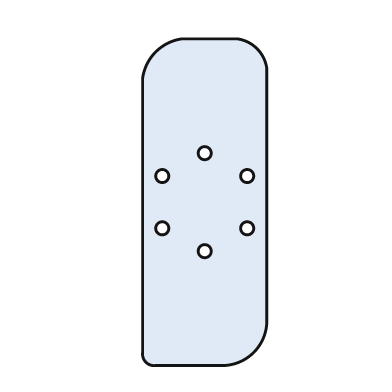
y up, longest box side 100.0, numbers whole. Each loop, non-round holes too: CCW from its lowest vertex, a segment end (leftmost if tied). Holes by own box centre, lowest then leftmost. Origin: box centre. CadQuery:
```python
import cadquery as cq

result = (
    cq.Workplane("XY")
    .moveTo(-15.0, -50.0)
    .lineTo(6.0, -50.0)
    .threePointArc((15.0, -46.0), (19.0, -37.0))
    .lineTo(19.0, 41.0)
    .threePointArc((16.0, 47.0), (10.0, 50.0))
    .lineTo(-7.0, 50.0)
    .threePointArc((-15.0, 46.0), (-19.0, 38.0))
    .lineTo(-19.0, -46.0)
    .threePointArc((-18.0, -49.0), (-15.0, -50.0))
    .close()
    .moveTo(0.0, -15.0)
    .circle(2.0)
    .moveTo(-13.0, -8.0)
    .circle(2.0)
    .moveTo(13.0, -8.0)
    .circle(2.0)
    .moveTo(-13.0, 8.0)
    .circle(2.0)
    .moveTo(13.0, 8.0)
    .circle(2.0)
    .moveTo(0.0, 15.0)
    .circle(2.0)
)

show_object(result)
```